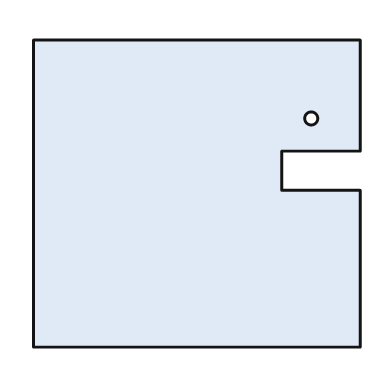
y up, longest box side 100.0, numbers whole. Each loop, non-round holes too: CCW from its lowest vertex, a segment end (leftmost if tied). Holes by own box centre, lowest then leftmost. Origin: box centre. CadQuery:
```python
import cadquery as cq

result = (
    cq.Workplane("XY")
    .moveTo(-50.0, -47.0)
    .lineTo(50.0, -47.0)
    .lineTo(50.0, 1.0)
    .lineTo(26.0, 1.0)
    .lineTo(26.0, 13.0)
    .lineTo(50.0, 13.0)
    .lineTo(50.0, 47.0)
    .lineTo(-50.0, 47.0)
    .close()
    .moveTo(35.0, 23.0)
    .circle(2.0)
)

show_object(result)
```